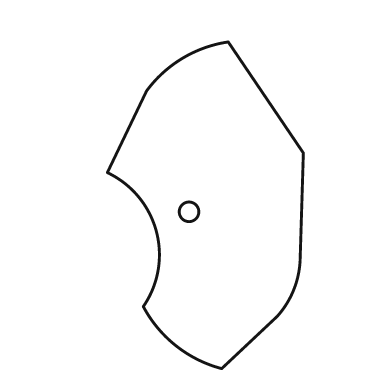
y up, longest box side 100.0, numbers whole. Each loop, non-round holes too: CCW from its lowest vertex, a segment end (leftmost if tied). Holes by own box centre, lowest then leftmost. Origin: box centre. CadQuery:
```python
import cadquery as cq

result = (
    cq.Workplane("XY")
    .moveTo(5.0, -50.0)
    .lineTo(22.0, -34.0)
    .threePointArc((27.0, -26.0), (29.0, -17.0))
    .lineTo(30.0, 16.0)
    .lineTo(7.0, 50.0)
    .threePointArc((-7.0, 45.0), (-18.0, 35.0))
    .lineTo(-30.0, 10.0)
    .threePointArc((-15.0, -8.0), (-19.0, -31.0))
    .threePointArc((-9.0, -43.0), (5.0, -50.0))
    .close()
    .moveTo(-5.0, -2.0)
    .circle(3.0)
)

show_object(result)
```